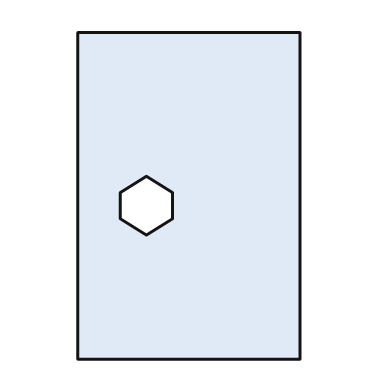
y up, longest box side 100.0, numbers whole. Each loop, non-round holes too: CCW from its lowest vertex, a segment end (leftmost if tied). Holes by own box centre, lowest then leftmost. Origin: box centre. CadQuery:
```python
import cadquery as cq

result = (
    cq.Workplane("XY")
    .moveTo(-34.0, -50.0)
    .lineTo(34.0, -50.0)
    .lineTo(34.0, 50.0)
    .lineTo(-34.0, 50.0)
    .close()
    .moveTo(-13.0, -12.0)
    .lineTo(-5.0, -7.0)
    .lineTo(-5.0, 1.0)
    .lineTo(-13.0, 6.0)
    .lineTo(-21.0, 1.0)
    .lineTo(-21.0, -7.0)
    .close()
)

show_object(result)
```